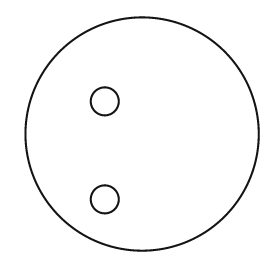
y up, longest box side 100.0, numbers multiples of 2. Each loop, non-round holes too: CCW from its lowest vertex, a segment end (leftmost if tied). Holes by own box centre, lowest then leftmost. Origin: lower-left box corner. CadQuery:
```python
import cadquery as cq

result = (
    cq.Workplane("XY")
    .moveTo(50.0, 50.0)
    .circle(50.0)
    .moveTo(34.0, 22.0)
    .circle(6.0)
    .moveTo(34.0, 64.0)
    .circle(6.0)
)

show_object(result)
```